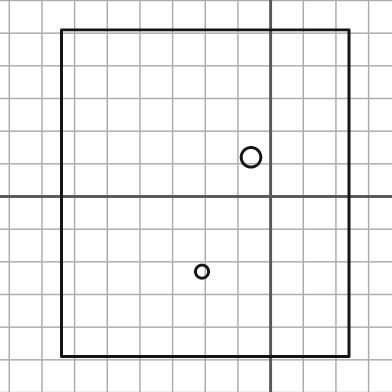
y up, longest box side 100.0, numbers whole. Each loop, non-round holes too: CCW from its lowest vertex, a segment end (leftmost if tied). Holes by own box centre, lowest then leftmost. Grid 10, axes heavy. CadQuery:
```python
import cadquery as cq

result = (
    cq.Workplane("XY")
    .moveTo(-64.0, -49.0)
    .lineTo(24.0, -49.0)
    .lineTo(24.0, 51.0)
    .lineTo(-64.0, 51.0)
    .close()
    .moveTo(-21.0, -23.0)
    .circle(2.0)
    .moveTo(-6.0, 12.0)
    .circle(3.0)
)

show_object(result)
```